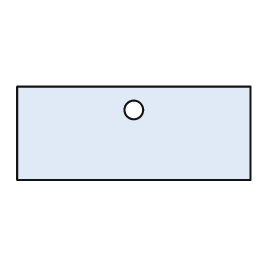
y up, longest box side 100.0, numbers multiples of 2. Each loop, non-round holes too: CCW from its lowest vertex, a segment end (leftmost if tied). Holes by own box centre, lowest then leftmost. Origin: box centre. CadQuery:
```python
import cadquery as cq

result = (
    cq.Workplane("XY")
    .moveTo(-50.0, -20.0)
    .lineTo(50.0, -20.0)
    .lineTo(50.0, 20.0)
    .lineTo(-50.0, 20.0)
    .close()
    .moveTo(0.0, 10.0)
    .circle(4.0)
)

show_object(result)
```